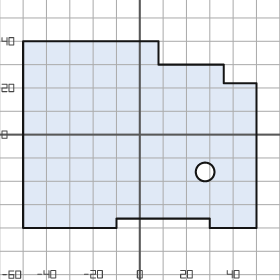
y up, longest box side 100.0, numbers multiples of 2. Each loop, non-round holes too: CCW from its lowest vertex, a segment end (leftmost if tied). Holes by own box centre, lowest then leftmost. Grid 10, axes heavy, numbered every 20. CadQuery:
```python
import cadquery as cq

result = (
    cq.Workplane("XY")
    .moveTo(-50.0, -40.0)
    .lineTo(-10.0, -40.0)
    .lineTo(-10.0, -36.0)
    .lineTo(30.0, -36.0)
    .lineTo(30.0, -40.0)
    .lineTo(50.0, -40.0)
    .lineTo(50.0, 22.0)
    .lineTo(36.0, 22.0)
    .lineTo(36.0, 30.0)
    .lineTo(8.0, 30.0)
    .lineTo(8.0, 40.0)
    .lineTo(-50.0, 40.0)
    .close()
    .moveTo(28.0, -16.0)
    .circle(4.0)
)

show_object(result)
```